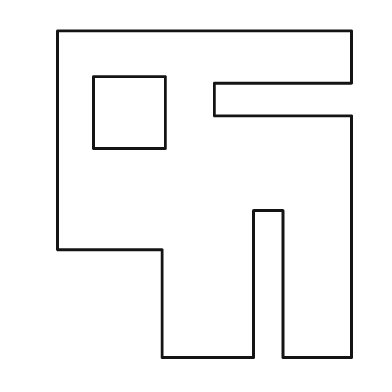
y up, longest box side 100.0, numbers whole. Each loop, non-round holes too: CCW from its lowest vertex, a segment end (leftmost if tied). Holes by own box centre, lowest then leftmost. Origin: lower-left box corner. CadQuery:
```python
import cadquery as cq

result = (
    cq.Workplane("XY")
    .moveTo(32.0, 0.0)
    .lineTo(60.0, 0.0)
    .lineTo(60.0, 45.0)
    .lineTo(69.0, 45.0)
    .lineTo(69.0, 0.0)
    .lineTo(90.0, 0.0)
    .lineTo(90.0, 74.0)
    .lineTo(48.0, 74.0)
    .lineTo(48.0, 84.0)
    .lineTo(90.0, 84.0)
    .lineTo(90.0, 100.0)
    .lineTo(0.0, 100.0)
    .lineTo(0.0, 33.0)
    .lineTo(32.0, 33.0)
    .close()
    .moveTo(11.0, 64.0)
    .lineTo(33.0, 64.0)
    .lineTo(33.0, 86.0)
    .lineTo(11.0, 86.0)
    .close()
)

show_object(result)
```